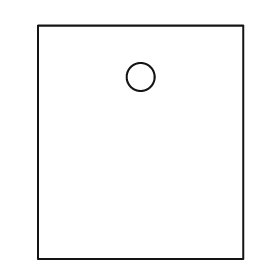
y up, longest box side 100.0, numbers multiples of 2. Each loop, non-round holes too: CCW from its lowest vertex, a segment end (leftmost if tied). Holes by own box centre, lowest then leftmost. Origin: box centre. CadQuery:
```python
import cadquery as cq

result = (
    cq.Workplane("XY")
    .moveTo(-44.0, -50.0)
    .lineTo(44.0, -50.0)
    .lineTo(44.0, 50.0)
    .lineTo(-44.0, 50.0)
    .close()
    .moveTo(0.0, 28.0)
    .circle(6.0)
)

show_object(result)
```